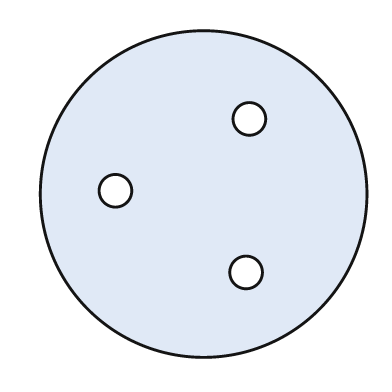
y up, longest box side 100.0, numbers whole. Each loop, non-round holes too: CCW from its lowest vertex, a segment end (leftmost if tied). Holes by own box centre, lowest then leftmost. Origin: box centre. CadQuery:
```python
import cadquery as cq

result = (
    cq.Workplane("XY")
    .moveTo(0.0, 0.0)
    .circle(50.0)
    .moveTo(13.0, -24.0)
    .circle(5.0)
    .moveTo(-27.0, 1.0)
    .circle(5.0)
    .moveTo(14.0, 23.0)
    .circle(5.0)
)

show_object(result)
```